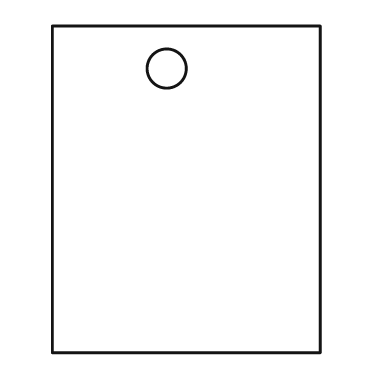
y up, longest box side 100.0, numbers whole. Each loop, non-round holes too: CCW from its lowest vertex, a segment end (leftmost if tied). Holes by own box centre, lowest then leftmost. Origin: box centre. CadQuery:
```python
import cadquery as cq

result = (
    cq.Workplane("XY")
    .moveTo(-41.0, -50.0)
    .lineTo(41.0, -50.0)
    .lineTo(41.0, 50.0)
    .lineTo(-41.0, 50.0)
    .close()
    .moveTo(-6.0, 37.0)
    .circle(6.0)
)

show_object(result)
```